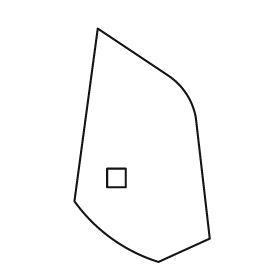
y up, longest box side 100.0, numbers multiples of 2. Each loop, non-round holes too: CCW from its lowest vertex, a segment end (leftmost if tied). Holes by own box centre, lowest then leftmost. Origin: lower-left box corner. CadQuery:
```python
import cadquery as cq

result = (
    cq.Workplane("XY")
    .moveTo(36.0, 0.0)
    .lineTo(58.0, 10.0)
    .lineTo(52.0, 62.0)
    .threePointArc((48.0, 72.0), (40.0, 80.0))
    .lineTo(10.0, 100.0)
    .lineTo(0.0, 26.0)
    .threePointArc((16.0, 10.0), (36.0, 0.0))
    .close()
    .moveTo(14.0, 32.0)
    .lineTo(22.0, 32.0)
    .lineTo(22.0, 40.0)
    .lineTo(14.0, 40.0)
    .close()
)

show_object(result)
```